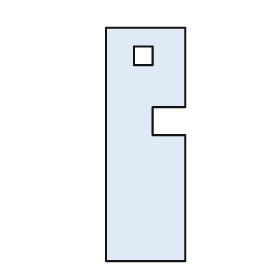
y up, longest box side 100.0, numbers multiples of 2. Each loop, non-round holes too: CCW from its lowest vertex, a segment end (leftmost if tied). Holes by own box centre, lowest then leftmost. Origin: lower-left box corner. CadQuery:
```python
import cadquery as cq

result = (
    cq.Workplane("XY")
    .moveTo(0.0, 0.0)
    .lineTo(34.0, 0.0)
    .lineTo(34.0, 54.0)
    .lineTo(20.0, 54.0)
    .lineTo(20.0, 66.0)
    .lineTo(34.0, 66.0)
    .lineTo(34.0, 100.0)
    .lineTo(0.0, 100.0)
    .close()
    .moveTo(12.0, 84.0)
    .lineTo(20.0, 84.0)
    .lineTo(20.0, 92.0)
    .lineTo(12.0, 92.0)
    .close()
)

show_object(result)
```